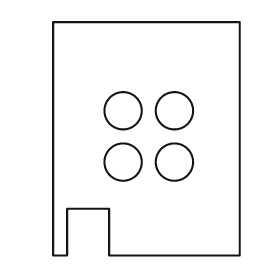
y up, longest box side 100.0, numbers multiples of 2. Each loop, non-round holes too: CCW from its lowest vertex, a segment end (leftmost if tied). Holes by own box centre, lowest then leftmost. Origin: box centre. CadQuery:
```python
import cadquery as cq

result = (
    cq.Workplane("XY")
    .moveTo(-40.0, -50.0)
    .lineTo(-34.0, -50.0)
    .lineTo(-34.0, -30.0)
    .lineTo(-16.0, -30.0)
    .lineTo(-16.0, -50.0)
    .lineTo(40.0, -50.0)
    .lineTo(40.0, 50.0)
    .lineTo(-40.0, 50.0)
    .close()
    .moveTo(-10.0, -10.0)
    .circle(8.0)
    .moveTo(12.0, -10.0)
    .circle(8.0)
    .moveTo(-10.0, 12.0)
    .circle(8.0)
    .moveTo(12.0, 12.0)
    .circle(8.0)
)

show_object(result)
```